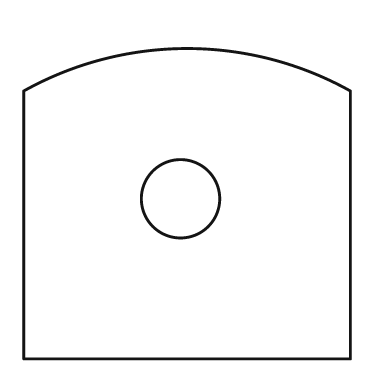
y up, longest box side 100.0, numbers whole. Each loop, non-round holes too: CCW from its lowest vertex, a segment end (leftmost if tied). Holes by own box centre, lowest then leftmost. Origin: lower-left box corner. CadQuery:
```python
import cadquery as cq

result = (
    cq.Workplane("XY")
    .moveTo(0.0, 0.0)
    .lineTo(100.0, 0.0)
    .lineTo(100.0, 82.0)
    .threePointArc((50.0, 95.0), (0.0, 82.0))
    .close()
    .moveTo(48.0, 49.0)
    .circle(12.0)
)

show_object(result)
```